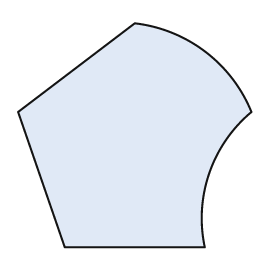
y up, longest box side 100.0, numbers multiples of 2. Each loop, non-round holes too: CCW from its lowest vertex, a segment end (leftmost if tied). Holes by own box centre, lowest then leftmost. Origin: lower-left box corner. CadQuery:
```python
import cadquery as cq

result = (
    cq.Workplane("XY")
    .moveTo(20.0, 0.0)
    .lineTo(80.0, 0.0)
    .threePointArc((82.0, 32.0), (100.0, 58.0))
    .threePointArc((80.0, 84.0), (50.0, 96.0))
    .lineTo(0.0, 58.0)
    .close()
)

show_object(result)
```